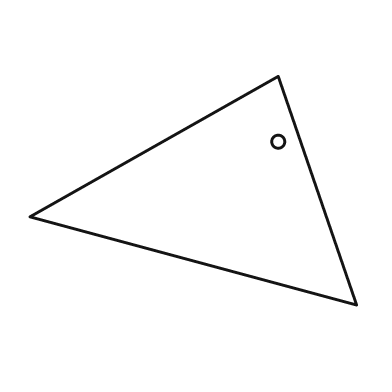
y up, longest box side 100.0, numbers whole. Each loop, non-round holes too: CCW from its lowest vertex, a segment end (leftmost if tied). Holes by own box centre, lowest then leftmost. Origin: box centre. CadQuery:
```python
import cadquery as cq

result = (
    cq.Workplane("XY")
    .moveTo(50.0, -35.0)
    .lineTo(26.0, 35.0)
    .lineTo(-50.0, -8.0)
    .close()
    .moveTo(26.0, 15.0)
    .circle(2.0)
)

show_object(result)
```